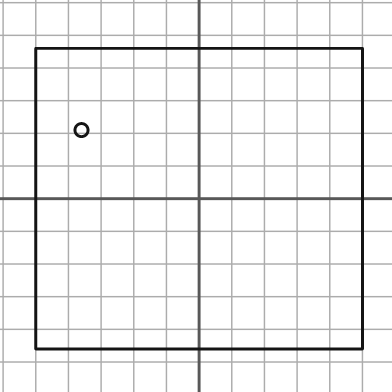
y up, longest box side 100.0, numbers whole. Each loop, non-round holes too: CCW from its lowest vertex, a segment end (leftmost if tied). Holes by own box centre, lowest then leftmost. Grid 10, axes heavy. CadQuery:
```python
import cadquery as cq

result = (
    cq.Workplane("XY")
    .moveTo(-50.0, -46.0)
    .lineTo(50.0, -46.0)
    .lineTo(50.0, 46.0)
    .lineTo(-50.0, 46.0)
    .close()
    .moveTo(-36.0, 21.0)
    .circle(2.0)
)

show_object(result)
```